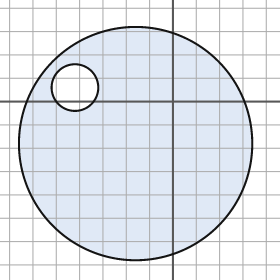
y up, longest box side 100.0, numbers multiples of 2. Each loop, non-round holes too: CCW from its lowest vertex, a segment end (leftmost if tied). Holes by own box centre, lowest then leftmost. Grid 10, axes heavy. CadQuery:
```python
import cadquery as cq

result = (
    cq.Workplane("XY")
    .moveTo(-16.0, -18.0)
    .circle(50.0)
    .moveTo(-42.0, 6.0)
    .circle(10.0)
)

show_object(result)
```